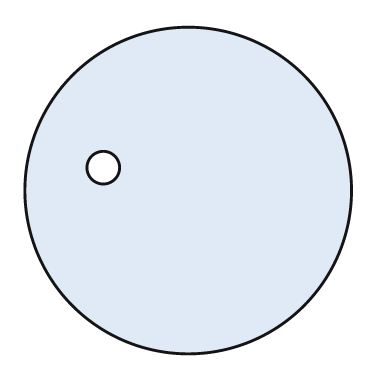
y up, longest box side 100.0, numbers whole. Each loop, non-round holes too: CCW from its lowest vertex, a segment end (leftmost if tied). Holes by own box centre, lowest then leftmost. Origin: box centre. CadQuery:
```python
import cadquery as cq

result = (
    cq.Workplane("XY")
    .moveTo(0.0, 0.0)
    .circle(50.0)
    .moveTo(-26.0, 7.0)
    .circle(5.0)
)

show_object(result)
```